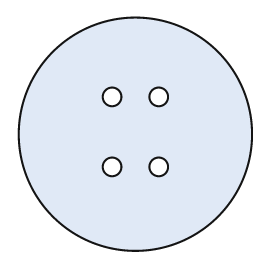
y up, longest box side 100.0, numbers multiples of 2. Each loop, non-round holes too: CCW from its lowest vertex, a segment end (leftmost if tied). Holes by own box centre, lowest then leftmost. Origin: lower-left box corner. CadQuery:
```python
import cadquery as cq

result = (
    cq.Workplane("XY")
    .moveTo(50.0, 50.0)
    .circle(50.0)
    .moveTo(40.0, 36.0)
    .circle(4.0)
    .moveTo(60.0, 36.0)
    .circle(4.0)
    .moveTo(40.0, 66.0)
    .circle(4.0)
    .moveTo(60.0, 66.0)
    .circle(4.0)
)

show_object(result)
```